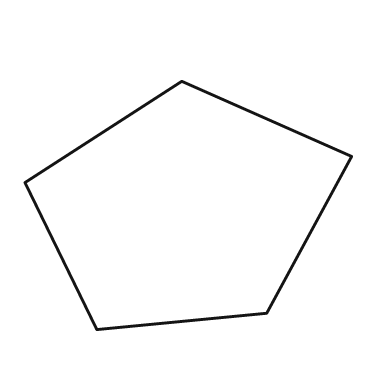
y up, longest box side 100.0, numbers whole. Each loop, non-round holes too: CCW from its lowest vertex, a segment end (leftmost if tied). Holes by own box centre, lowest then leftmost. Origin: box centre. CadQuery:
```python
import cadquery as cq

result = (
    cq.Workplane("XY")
    .moveTo(-28.0, -38.0)
    .lineTo(24.0, -33.0)
    .lineTo(50.0, 15.0)
    .lineTo(-2.0, 38.0)
    .lineTo(-50.0, 7.0)
    .close()
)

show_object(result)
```